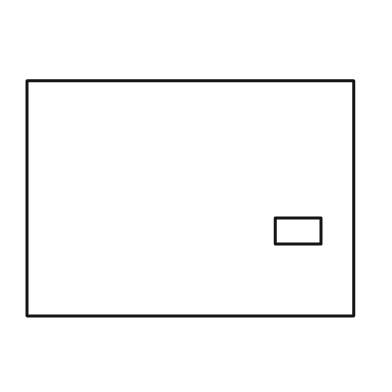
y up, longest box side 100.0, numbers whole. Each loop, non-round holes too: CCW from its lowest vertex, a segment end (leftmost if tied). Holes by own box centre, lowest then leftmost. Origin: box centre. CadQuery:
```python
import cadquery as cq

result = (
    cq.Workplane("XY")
    .moveTo(-50.0, -36.0)
    .lineTo(50.0, -36.0)
    .lineTo(50.0, 36.0)
    .lineTo(-50.0, 36.0)
    .close()
    .moveTo(26.0, -14.0)
    .lineTo(40.0, -14.0)
    .lineTo(40.0, -6.0)
    .lineTo(26.0, -6.0)
    .close()
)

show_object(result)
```